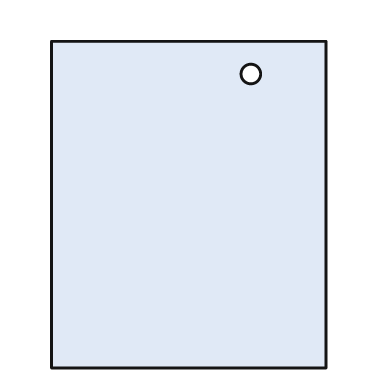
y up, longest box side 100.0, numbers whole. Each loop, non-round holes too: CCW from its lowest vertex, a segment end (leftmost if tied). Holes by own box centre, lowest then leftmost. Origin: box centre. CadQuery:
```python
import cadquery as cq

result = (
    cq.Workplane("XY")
    .moveTo(-42.0, -50.0)
    .lineTo(42.0, -50.0)
    .lineTo(42.0, 50.0)
    .lineTo(-42.0, 50.0)
    .close()
    .moveTo(19.0, 40.0)
    .circle(3.0)
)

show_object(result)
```